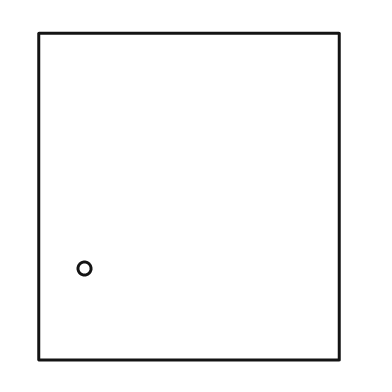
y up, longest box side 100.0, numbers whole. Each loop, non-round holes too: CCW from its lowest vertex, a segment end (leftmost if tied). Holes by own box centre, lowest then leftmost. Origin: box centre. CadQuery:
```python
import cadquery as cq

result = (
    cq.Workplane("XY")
    .moveTo(-46.0, -50.0)
    .lineTo(46.0, -50.0)
    .lineTo(46.0, 50.0)
    .lineTo(-46.0, 50.0)
    .close()
    .moveTo(-32.0, -22.0)
    .circle(2.0)
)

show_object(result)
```